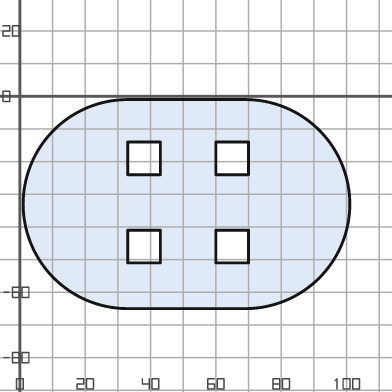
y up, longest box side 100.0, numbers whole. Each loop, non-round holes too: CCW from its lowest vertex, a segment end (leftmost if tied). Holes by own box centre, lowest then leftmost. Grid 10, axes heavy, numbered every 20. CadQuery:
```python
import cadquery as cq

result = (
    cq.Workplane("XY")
    .moveTo(33.0, -65.0)
    .lineTo(69.0, -65.0)
    .threePointArc((101.0, -33.0), (69.0, -1.0))
    .lineTo(33.0, -1.0)
    .threePointArc((1.0, -33.0), (33.0, -65.0))
    .close()
    .moveTo(33.0, -51.0)
    .lineTo(43.0, -51.0)
    .lineTo(43.0, -41.0)
    .lineTo(33.0, -41.0)
    .close()
    .moveTo(60.0, -51.0)
    .lineTo(70.0, -51.0)
    .lineTo(70.0, -41.0)
    .lineTo(60.0, -41.0)
    .close()
    .moveTo(33.0, -24.0)
    .lineTo(43.0, -24.0)
    .lineTo(43.0, -14.0)
    .lineTo(33.0, -14.0)
    .close()
    .moveTo(60.0, -24.0)
    .lineTo(70.0, -24.0)
    .lineTo(70.0, -14.0)
    .lineTo(60.0, -14.0)
    .close()
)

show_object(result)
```